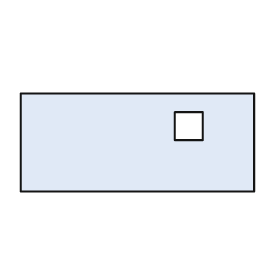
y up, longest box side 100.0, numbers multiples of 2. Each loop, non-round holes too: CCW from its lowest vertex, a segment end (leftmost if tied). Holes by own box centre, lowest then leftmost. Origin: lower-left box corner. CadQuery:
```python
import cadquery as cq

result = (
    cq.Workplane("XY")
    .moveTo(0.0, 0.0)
    .lineTo(100.0, 0.0)
    .lineTo(100.0, 42.0)
    .lineTo(0.0, 42.0)
    .close()
    .moveTo(66.0, 22.0)
    .lineTo(78.0, 22.0)
    .lineTo(78.0, 34.0)
    .lineTo(66.0, 34.0)
    .close()
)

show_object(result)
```